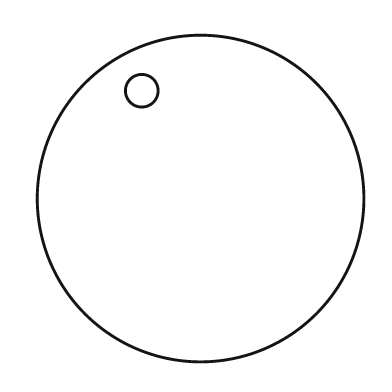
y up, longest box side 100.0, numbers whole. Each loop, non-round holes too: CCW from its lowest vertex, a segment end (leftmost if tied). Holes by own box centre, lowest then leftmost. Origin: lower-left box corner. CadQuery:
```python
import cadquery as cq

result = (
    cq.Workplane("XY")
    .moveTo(50.0, 50.0)
    .circle(50.0)
    .moveTo(32.0, 83.0)
    .circle(5.0)
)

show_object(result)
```